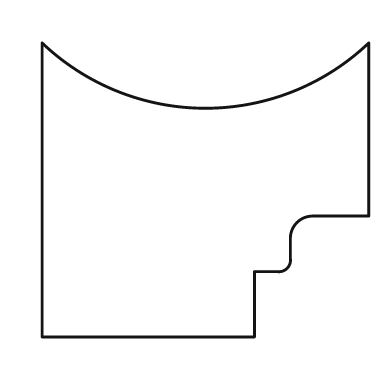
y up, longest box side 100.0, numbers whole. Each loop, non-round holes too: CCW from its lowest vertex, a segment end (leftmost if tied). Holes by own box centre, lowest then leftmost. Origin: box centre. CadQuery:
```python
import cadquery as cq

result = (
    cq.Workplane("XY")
    .moveTo(-50.0, -45.0)
    .lineTo(15.0, -45.0)
    .lineTo(15.0, -25.0)
    .lineTo(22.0, -25.0)
    .threePointArc((25.0, -24.0), (26.0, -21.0))
    .lineTo(26.0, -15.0)
    .threePointArc((28.0, -10.0), (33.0, -8.0))
    .lineTo(50.0, -8.0)
    .lineTo(50.0, 45.0)
    .threePointArc((0.0, 25.0), (-50.0, 45.0))
    .close()
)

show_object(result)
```